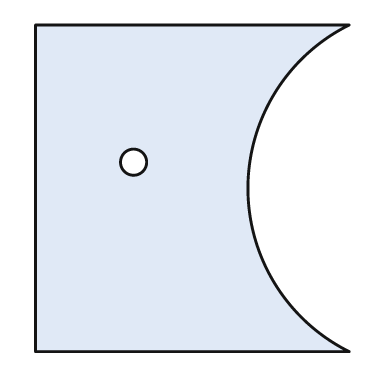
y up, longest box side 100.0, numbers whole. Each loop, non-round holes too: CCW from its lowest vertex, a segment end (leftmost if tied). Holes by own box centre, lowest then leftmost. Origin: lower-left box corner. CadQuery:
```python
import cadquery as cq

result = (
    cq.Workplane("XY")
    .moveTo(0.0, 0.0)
    .lineTo(96.0, 0.0)
    .threePointArc((65.0, 50.0), (96.0, 100.0))
    .lineTo(0.0, 100.0)
    .close()
    .moveTo(30.0, 58.0)
    .circle(4.0)
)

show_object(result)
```